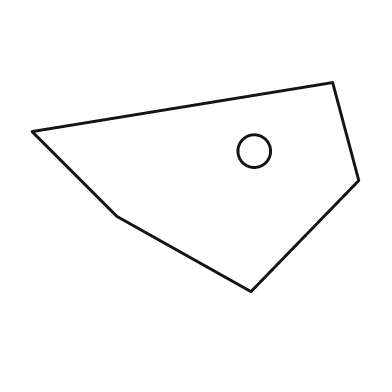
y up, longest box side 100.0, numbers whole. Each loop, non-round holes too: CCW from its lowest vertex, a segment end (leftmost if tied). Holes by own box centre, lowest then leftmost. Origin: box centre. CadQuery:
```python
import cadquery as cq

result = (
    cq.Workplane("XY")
    .moveTo(17.0, -32.0)
    .lineTo(50.0, 2.0)
    .lineTo(42.0, 32.0)
    .lineTo(-50.0, 17.0)
    .lineTo(-24.0, -9.0)
    .close()
    .moveTo(18.0, 11.0)
    .circle(5.0)
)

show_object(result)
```